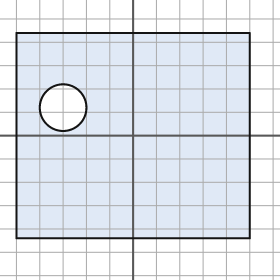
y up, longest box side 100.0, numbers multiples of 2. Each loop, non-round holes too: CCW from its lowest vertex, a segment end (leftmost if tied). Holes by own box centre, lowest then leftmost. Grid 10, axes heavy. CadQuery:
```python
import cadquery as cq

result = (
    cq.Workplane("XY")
    .moveTo(-50.0, -44.0)
    .lineTo(50.0, -44.0)
    .lineTo(50.0, 44.0)
    .lineTo(-50.0, 44.0)
    .close()
    .moveTo(-30.0, 12.0)
    .circle(10.0)
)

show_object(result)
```